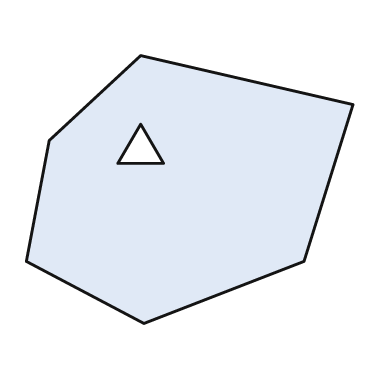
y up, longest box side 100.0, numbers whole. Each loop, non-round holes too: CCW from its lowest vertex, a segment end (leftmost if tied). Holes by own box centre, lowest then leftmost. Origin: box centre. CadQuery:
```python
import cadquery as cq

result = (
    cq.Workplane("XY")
    .moveTo(-14.0, -41.0)
    .lineTo(35.0, -22.0)
    .lineTo(50.0, 26.0)
    .lineTo(-15.0, 41.0)
    .lineTo(-43.0, 15.0)
    .lineTo(-50.0, -22.0)
    .close()
    .moveTo(-22.0, 8.0)
    .lineTo(-8.0, 8.0)
    .lineTo(-15.0, 20.0)
    .close()
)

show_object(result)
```